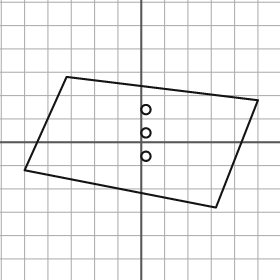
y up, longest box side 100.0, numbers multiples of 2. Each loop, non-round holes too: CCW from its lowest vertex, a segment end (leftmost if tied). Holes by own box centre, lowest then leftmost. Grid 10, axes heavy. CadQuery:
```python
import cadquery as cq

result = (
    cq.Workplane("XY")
    .moveTo(32.0, -28.0)
    .lineTo(50.0, 18.0)
    .lineTo(-32.0, 28.0)
    .lineTo(-50.0, -12.0)
    .close()
    .moveTo(2.0, -6.0)
    .circle(2.0)
    .moveTo(2.0, 4.0)
    .circle(2.0)
    .moveTo(2.0, 14.0)
    .circle(2.0)
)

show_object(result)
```